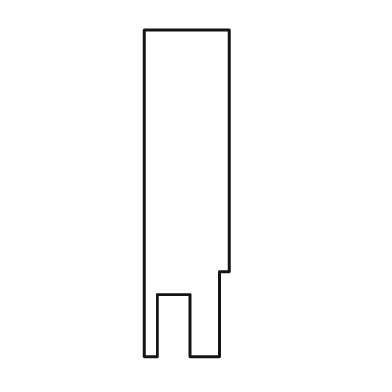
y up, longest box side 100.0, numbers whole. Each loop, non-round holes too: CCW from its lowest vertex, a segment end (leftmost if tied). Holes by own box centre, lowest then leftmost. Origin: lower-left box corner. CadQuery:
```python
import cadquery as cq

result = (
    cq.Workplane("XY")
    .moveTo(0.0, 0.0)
    .lineTo(4.0, 0.0)
    .lineTo(4.0, 19.0)
    .lineTo(14.0, 19.0)
    .lineTo(14.0, 0.0)
    .lineTo(23.0, 0.0)
    .lineTo(23.0, 26.0)
    .lineTo(26.0, 26.0)
    .lineTo(26.0, 100.0)
    .lineTo(0.0, 100.0)
    .close()
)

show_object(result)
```